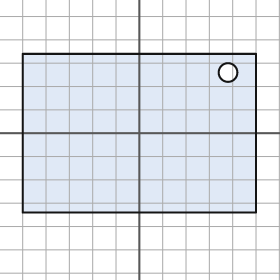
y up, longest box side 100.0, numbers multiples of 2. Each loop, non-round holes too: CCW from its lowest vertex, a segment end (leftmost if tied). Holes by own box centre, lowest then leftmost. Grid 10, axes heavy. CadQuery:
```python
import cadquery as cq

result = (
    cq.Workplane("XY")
    .moveTo(-50.0, -34.0)
    .lineTo(50.0, -34.0)
    .lineTo(50.0, 34.0)
    .lineTo(-50.0, 34.0)
    .close()
    .moveTo(38.0, 26.0)
    .circle(4.0)
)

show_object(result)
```